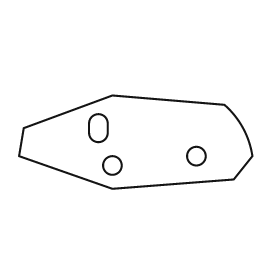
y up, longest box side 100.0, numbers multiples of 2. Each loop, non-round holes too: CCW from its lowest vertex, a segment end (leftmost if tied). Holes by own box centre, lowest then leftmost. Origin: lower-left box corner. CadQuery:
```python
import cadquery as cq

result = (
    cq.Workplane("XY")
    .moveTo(40.0, 0.0)
    .lineTo(92.0, 4.0)
    .lineTo(100.0, 14.0)
    .threePointArc((96.0, 26.0), (88.0, 36.0))
    .lineTo(40.0, 40.0)
    .lineTo(2.0, 26.0)
    .lineTo(0.0, 14.0)
    .close()
    .moveTo(40.0, 10.0)
    .circle(4.0)
    .moveTo(76.0, 14.0)
    .circle(4.0)
    .moveTo(30.0, 24.0)
    .threePointArc((34.0, 20.0), (38.0, 24.0))
    .lineTo(38.0, 28.0)
    .threePointArc((34.0, 32.0), (30.0, 28.0))
    .close()
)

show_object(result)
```